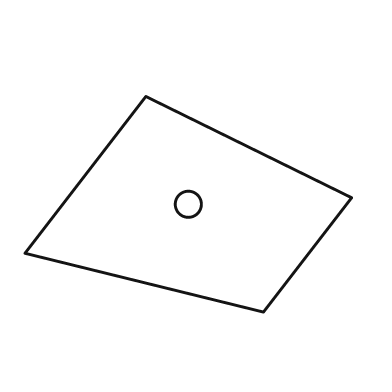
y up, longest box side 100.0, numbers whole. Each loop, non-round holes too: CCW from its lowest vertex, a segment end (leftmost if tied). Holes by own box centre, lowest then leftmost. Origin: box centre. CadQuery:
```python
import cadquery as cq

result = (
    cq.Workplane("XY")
    .moveTo(23.0, -33.0)
    .lineTo(50.0, 2.0)
    .lineTo(-13.0, 33.0)
    .lineTo(-50.0, -15.0)
    .close()
    .moveTo(0.0, 0.0)
    .circle(4.0)
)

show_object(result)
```